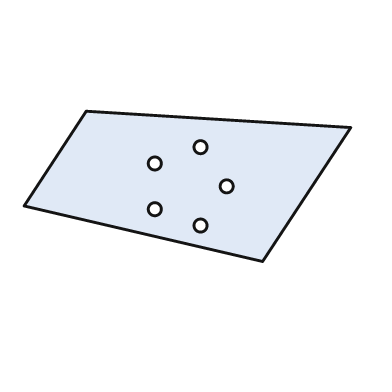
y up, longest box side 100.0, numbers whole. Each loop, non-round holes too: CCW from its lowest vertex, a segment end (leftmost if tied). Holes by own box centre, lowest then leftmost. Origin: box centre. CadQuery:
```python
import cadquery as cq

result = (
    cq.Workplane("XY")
    .moveTo(23.0, -23.0)
    .lineTo(50.0, 18.0)
    .lineTo(-31.0, 23.0)
    .lineTo(-50.0, -6.0)
    .close()
    .moveTo(4.0, -12.0)
    .circle(2.0)
    .moveTo(-10.0, -7.0)
    .circle(2.0)
    .moveTo(12.0, 0.0)
    .circle(2.0)
    .moveTo(-10.0, 7.0)
    .circle(2.0)
    .moveTo(4.0, 12.0)
    .circle(2.0)
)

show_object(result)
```